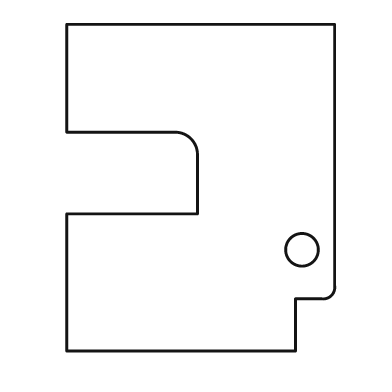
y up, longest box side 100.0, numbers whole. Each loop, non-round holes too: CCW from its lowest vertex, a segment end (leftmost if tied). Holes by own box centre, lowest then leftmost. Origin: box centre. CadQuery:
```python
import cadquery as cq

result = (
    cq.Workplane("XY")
    .moveTo(-41.0, -50.0)
    .lineTo(29.0, -50.0)
    .lineTo(29.0, -34.0)
    .lineTo(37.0, -34.0)
    .threePointArc((40.0, -33.0), (41.0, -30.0))
    .lineTo(41.0, 50.0)
    .lineTo(-41.0, 50.0)
    .lineTo(-41.0, 17.0)
    .lineTo(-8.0, 17.0)
    .threePointArc((-3.0, 15.0), (-1.0, 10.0))
    .lineTo(-1.0, -8.0)
    .lineTo(-41.0, -8.0)
    .close()
    .moveTo(31.0, -19.0)
    .circle(5.0)
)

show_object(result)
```